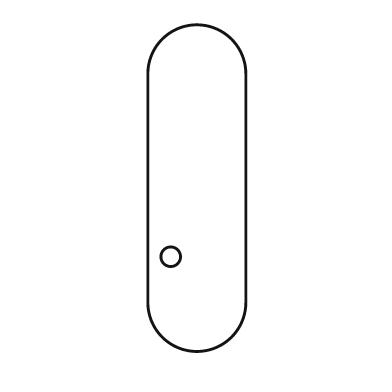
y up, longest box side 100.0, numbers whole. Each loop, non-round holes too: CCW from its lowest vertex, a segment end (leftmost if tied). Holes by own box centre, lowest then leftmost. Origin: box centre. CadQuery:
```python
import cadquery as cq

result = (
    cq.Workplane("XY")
    .moveTo(-15.0, -35.0)
    .threePointArc((0.0, -50.0), (15.0, -35.0))
    .lineTo(15.0, 35.0)
    .threePointArc((0.0, 50.0), (-15.0, 35.0))
    .close()
    .moveTo(-8.0, -21.0)
    .circle(3.0)
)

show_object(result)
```